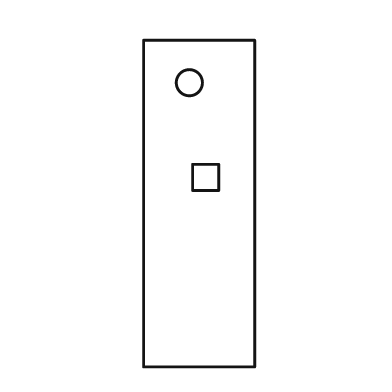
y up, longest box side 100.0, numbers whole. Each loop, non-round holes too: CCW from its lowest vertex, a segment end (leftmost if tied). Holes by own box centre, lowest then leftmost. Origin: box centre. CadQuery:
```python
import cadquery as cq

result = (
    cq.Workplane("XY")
    .moveTo(-17.0, -50.0)
    .lineTo(17.0, -50.0)
    .lineTo(17.0, 50.0)
    .lineTo(-17.0, 50.0)
    .close()
    .moveTo(-2.0, 4.0)
    .lineTo(6.0, 4.0)
    .lineTo(6.0, 12.0)
    .lineTo(-2.0, 12.0)
    .close()
    .moveTo(-3.0, 37.0)
    .circle(4.0)
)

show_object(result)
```